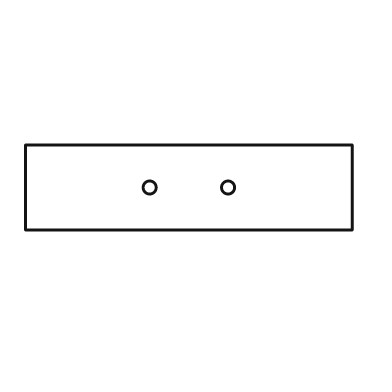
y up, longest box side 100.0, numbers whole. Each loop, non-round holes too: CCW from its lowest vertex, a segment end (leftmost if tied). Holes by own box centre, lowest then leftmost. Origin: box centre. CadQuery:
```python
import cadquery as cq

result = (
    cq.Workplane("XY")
    .moveTo(-50.0, -13.0)
    .lineTo(50.0, -13.0)
    .lineTo(50.0, 13.0)
    .lineTo(-50.0, 13.0)
    .close()
    .moveTo(-12.0, 0.0)
    .circle(2.0)
    .moveTo(12.0, 0.0)
    .circle(2.0)
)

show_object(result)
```